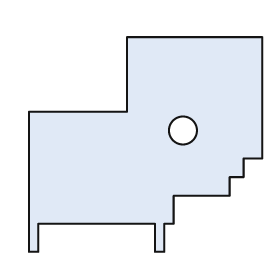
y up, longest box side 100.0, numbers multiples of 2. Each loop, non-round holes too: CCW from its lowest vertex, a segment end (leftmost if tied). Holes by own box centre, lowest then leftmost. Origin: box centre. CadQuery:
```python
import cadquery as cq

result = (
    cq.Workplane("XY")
    .moveTo(-50.0, -46.0)
    .lineTo(-46.0, -46.0)
    .lineTo(-46.0, -34.0)
    .lineTo(4.0, -34.0)
    .lineTo(4.0, -46.0)
    .lineTo(8.0, -46.0)
    .lineTo(8.0, -34.0)
    .lineTo(12.0, -34.0)
    .lineTo(12.0, -22.0)
    .lineTo(36.0, -22.0)
    .lineTo(36.0, -14.0)
    .lineTo(42.0, -14.0)
    .lineTo(42.0, -6.0)
    .lineTo(50.0, -6.0)
    .lineTo(50.0, 46.0)
    .lineTo(-8.0, 46.0)
    .lineTo(-8.0, 14.0)
    .lineTo(-50.0, 14.0)
    .close()
    .moveTo(16.0, 6.0)
    .circle(6.0)
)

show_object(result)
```